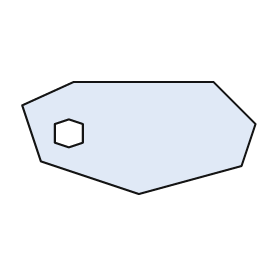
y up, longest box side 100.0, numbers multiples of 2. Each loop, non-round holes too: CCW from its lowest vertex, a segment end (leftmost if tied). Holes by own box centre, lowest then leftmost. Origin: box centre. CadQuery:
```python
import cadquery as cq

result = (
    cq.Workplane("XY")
    .moveTo(0.0, -24.0)
    .lineTo(44.0, -12.0)
    .lineTo(50.0, 6.0)
    .lineTo(32.0, 24.0)
    .lineTo(-28.0, 24.0)
    .lineTo(-50.0, 14.0)
    .lineTo(-42.0, -10.0)
    .close()
    .moveTo(-30.0, -4.0)
    .lineTo(-24.0, -2.0)
    .lineTo(-24.0, 6.0)
    .lineTo(-30.0, 8.0)
    .lineTo(-36.0, 6.0)
    .lineTo(-36.0, -2.0)
    .close()
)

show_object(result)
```